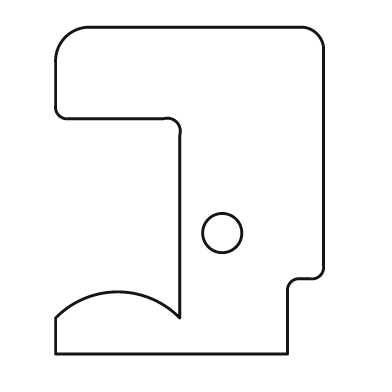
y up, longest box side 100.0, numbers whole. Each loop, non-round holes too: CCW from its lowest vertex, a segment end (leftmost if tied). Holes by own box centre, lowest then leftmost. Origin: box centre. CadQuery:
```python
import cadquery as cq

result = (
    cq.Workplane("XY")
    .moveTo(-41.0, -50.0)
    .lineTo(30.0, -50.0)
    .lineTo(30.0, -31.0)
    .threePointArc((31.0, -28.0), (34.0, -27.0))
    .lineTo(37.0, -27.0)
    .threePointArc((40.0, -26.0), (41.0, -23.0))
    .lineTo(41.0, 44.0)
    .threePointArc((39.0, 48.0), (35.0, 50.0))
    .lineTo(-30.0, 50.0)
    .threePointArc((-38.0, 47.0), (-41.0, 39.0))
    .lineTo(-41.0, 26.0)
    .threePointArc((-40.0, 23.0), (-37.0, 22.0))
    .lineTo(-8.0, 22.0)
    .threePointArc((-4.0, 21.0), (-3.0, 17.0))
    .lineTo(-3.0, -39.0)
    .threePointArc((-22.0, -31.0), (-41.0, -39.0))
    .close()
    .moveTo(10.0, -13.0)
    .circle(6.0)
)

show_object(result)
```